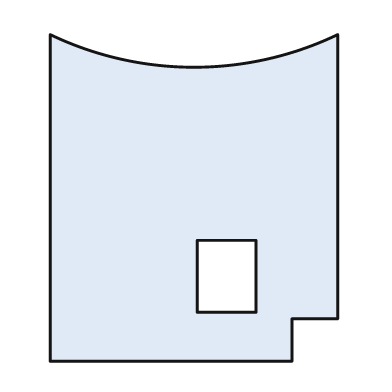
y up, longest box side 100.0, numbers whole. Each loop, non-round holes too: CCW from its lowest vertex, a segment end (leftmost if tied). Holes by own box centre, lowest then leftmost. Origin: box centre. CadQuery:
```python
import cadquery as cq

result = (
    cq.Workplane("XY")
    .moveTo(-44.0, -50.0)
    .lineTo(30.0, -50.0)
    .lineTo(30.0, -37.0)
    .lineTo(44.0, -37.0)
    .lineTo(44.0, 50.0)
    .threePointArc((0.0, 40.0), (-44.0, 50.0))
    .close()
    .moveTo(1.0, -35.0)
    .lineTo(19.0, -35.0)
    .lineTo(19.0, -13.0)
    .lineTo(1.0, -13.0)
    .close()
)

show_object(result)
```